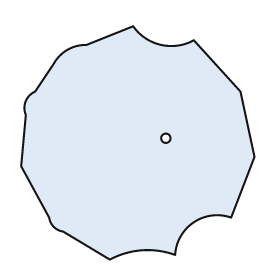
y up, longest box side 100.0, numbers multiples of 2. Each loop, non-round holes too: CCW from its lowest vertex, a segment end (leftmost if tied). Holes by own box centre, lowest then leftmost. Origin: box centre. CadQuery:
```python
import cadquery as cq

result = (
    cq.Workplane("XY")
    .moveTo(-12.0, -50.0)
    .threePointArc((2.0, -46.0), (16.0, -48.0))
    .threePointArc((24.0, -34.0), (40.0, -32.0))
    .lineTo(50.0, -6.0)
    .lineTo(44.0, 22.0)
    .lineTo(24.0, 44.0)
    .threePointArc((10.0, 42.0), (-2.0, 50.0))
    .lineTo(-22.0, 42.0)
    .threePointArc((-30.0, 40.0), (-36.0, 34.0))
    .lineTo(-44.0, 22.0)
    .threePointArc((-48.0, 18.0), (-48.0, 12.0))
    .lineTo(-50.0, -10.0)
    .lineTo(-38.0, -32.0)
    .threePointArc((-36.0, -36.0), (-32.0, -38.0))
    .close()
    .moveTo(12.0, 2.0)
    .circle(2.0)
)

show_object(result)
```